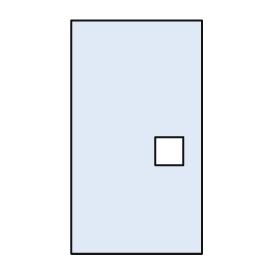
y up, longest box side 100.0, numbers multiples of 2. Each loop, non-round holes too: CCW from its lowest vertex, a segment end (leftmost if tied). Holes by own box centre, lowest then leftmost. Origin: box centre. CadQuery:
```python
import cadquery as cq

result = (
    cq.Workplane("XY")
    .moveTo(-28.0, -50.0)
    .lineTo(28.0, -50.0)
    .lineTo(28.0, 50.0)
    .lineTo(-28.0, 50.0)
    .close()
    .moveTo(8.0, -12.0)
    .lineTo(20.0, -12.0)
    .lineTo(20.0, 0.0)
    .lineTo(8.0, 0.0)
    .close()
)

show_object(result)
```